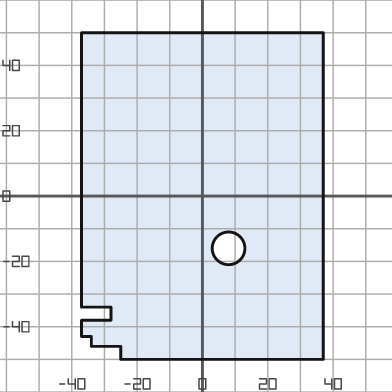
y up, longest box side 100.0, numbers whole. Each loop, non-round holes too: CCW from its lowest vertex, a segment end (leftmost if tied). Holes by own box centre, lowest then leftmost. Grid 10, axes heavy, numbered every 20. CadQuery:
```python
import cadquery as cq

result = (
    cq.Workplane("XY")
    .moveTo(-25.0, -50.0)
    .lineTo(37.0, -50.0)
    .lineTo(37.0, 50.0)
    .lineTo(-37.0, 50.0)
    .lineTo(-37.0, -34.0)
    .lineTo(-28.0, -34.0)
    .lineTo(-28.0, -38.0)
    .lineTo(-37.0, -38.0)
    .lineTo(-37.0, -43.0)
    .lineTo(-34.0, -43.0)
    .lineTo(-34.0, -46.0)
    .lineTo(-25.0, -46.0)
    .close()
    .moveTo(8.0, -16.0)
    .circle(5.0)
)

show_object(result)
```